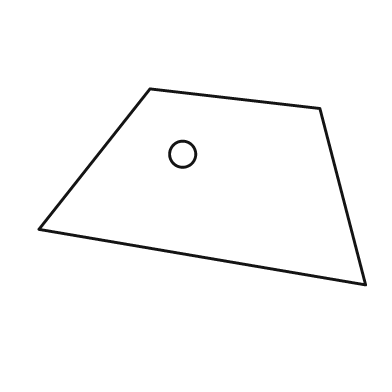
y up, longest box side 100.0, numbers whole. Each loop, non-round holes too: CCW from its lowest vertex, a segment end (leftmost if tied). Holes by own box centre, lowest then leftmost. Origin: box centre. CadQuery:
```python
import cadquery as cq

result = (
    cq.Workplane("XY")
    .moveTo(50.0, -30.0)
    .lineTo(36.0, 24.0)
    .lineTo(-16.0, 30.0)
    .lineTo(-50.0, -13.0)
    .close()
    .moveTo(-6.0, 10.0)
    .circle(4.0)
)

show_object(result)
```